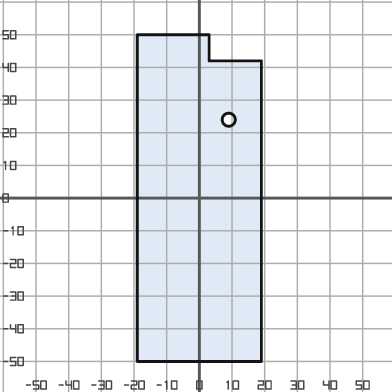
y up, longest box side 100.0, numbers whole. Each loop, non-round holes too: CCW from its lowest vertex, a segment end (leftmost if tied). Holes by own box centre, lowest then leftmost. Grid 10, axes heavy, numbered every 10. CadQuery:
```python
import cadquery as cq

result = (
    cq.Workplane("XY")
    .moveTo(-19.0, -50.0)
    .lineTo(19.0, -50.0)
    .lineTo(19.0, 42.0)
    .lineTo(3.0, 42.0)
    .lineTo(3.0, 50.0)
    .lineTo(-19.0, 50.0)
    .close()
    .moveTo(9.0, 24.0)
    .circle(2.0)
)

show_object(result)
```